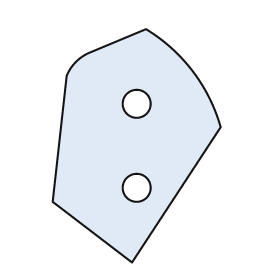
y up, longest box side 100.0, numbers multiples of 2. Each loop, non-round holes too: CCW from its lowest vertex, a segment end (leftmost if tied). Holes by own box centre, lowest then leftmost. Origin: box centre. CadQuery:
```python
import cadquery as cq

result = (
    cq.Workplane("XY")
    .moveTo(-2.0, -50.0)
    .lineTo(36.0, 8.0)
    .threePointArc((24.0, 32.0), (4.0, 50.0))
    .lineTo(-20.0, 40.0)
    .threePointArc((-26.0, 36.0), (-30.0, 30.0))
    .lineTo(-36.0, -24.0)
    .close()
    .moveTo(0.0, -18.0)
    .circle(6.0)
    .moveTo(0.0, 18.0)
    .circle(6.0)
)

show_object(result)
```